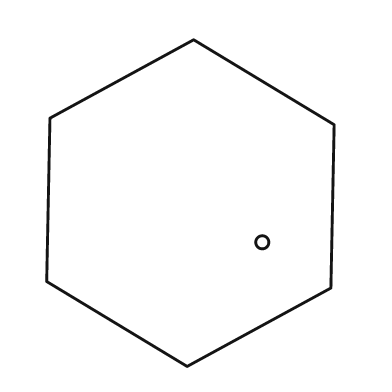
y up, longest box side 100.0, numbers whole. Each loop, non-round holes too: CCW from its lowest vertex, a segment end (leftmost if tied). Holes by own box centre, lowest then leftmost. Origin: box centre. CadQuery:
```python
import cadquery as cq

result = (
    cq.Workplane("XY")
    .moveTo(-1.0, -50.0)
    .lineTo(43.0, -26.0)
    .lineTo(44.0, 24.0)
    .lineTo(1.0, 50.0)
    .lineTo(-43.0, 26.0)
    .lineTo(-44.0, -24.0)
    .close()
    .moveTo(22.0, -12.0)
    .circle(2.0)
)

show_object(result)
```